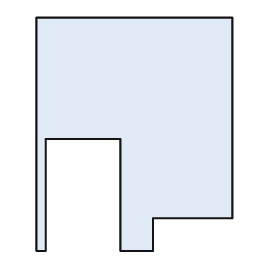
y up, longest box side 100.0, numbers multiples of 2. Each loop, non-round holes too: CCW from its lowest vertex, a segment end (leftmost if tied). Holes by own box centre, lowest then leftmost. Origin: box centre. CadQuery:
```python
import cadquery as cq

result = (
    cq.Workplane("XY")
    .moveTo(-42.0, -50.0)
    .lineTo(-38.0, -50.0)
    .lineTo(-38.0, -2.0)
    .lineTo(-6.0, -2.0)
    .lineTo(-6.0, -50.0)
    .lineTo(8.0, -50.0)
    .lineTo(8.0, -36.0)
    .lineTo(42.0, -36.0)
    .lineTo(42.0, 50.0)
    .lineTo(-42.0, 50.0)
    .close()
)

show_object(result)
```